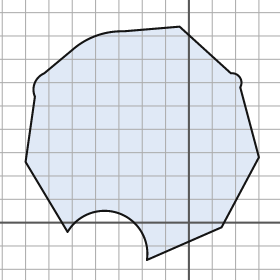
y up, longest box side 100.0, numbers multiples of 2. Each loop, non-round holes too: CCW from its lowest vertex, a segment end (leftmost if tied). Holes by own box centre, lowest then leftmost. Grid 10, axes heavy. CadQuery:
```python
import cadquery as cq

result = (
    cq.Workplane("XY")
    .moveTo(-18.0, -16.0)
    .lineTo(14.0, -2.0)
    .lineTo(30.0, 28.0)
    .lineTo(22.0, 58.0)
    .threePointArc((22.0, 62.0), (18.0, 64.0))
    .lineTo(-4.0, 84.0)
    .lineTo(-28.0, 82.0)
    .threePointArc((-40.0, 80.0), (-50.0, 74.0))
    .lineTo(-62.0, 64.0)
    .threePointArc((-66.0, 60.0), (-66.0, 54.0))
    .lineTo(-70.0, 26.0)
    .lineTo(-52.0, -4.0)
    .threePointArc((-30.0, 4.0), (-18.0, -16.0))
    .close()
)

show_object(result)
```